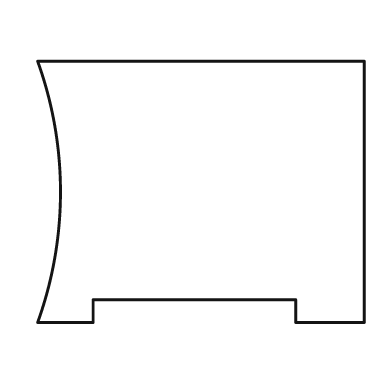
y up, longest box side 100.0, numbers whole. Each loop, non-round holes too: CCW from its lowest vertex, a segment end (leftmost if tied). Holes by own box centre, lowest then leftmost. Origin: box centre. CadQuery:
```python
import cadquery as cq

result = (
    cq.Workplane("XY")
    .moveTo(-50.0, -40.0)
    .lineTo(-33.0, -40.0)
    .lineTo(-33.0, -33.0)
    .lineTo(29.0, -33.0)
    .lineTo(29.0, -40.0)
    .lineTo(50.0, -40.0)
    .lineTo(50.0, 40.0)
    .lineTo(-50.0, 40.0)
    .threePointArc((-43.0, 0.0), (-50.0, -40.0))
    .close()
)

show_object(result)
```